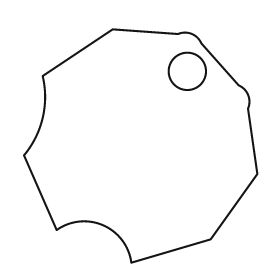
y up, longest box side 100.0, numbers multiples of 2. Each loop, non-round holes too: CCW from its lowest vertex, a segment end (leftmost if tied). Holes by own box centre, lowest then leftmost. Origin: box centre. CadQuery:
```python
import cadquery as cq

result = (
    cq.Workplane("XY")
    .moveTo(-4.0, -50.0)
    .lineTo(30.0, -40.0)
    .lineTo(50.0, -12.0)
    .lineTo(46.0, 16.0)
    .threePointArc((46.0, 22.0), (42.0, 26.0))
    .lineTo(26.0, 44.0)
    .threePointArc((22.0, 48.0), (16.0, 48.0))
    .lineTo(-12.0, 50.0)
    .lineTo(-42.0, 30.0)
    .threePointArc((-42.0, 12.0), (-50.0, -4.0))
    .lineTo(-36.0, -36.0)
    .threePointArc((-16.0, -34.0), (-4.0, -50.0))
    .close()
    .moveTo(20.0, 32.0)
    .circle(8.0)
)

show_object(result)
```